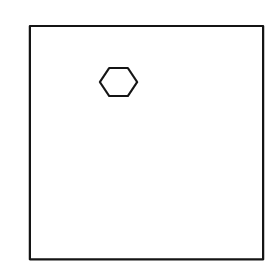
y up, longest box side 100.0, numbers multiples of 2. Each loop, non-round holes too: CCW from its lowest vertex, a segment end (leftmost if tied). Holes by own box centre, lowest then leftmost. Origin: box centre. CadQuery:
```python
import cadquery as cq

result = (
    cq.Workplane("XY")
    .moveTo(-50.0, -50.0)
    .lineTo(50.0, -50.0)
    .lineTo(50.0, 50.0)
    .lineTo(-50.0, 50.0)
    .close()
    .moveTo(-16.0, 20.0)
    .lineTo(-8.0, 20.0)
    .lineTo(-4.0, 26.0)
    .lineTo(-8.0, 32.0)
    .lineTo(-16.0, 32.0)
    .lineTo(-20.0, 26.0)
    .close()
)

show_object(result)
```